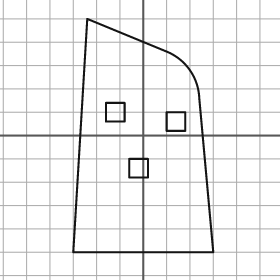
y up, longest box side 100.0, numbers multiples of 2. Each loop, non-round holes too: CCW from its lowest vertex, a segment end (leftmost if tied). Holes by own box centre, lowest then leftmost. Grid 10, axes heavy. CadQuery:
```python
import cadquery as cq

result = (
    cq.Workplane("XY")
    .moveTo(-30.0, -50.0)
    .lineTo(30.0, -50.0)
    .lineTo(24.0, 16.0)
    .threePointArc((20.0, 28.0), (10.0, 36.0))
    .lineTo(-24.0, 50.0)
    .close()
    .moveTo(-6.0, -18.0)
    .lineTo(2.0, -18.0)
    .lineTo(2.0, -10.0)
    .lineTo(-6.0, -10.0)
    .close()
    .moveTo(10.0, 2.0)
    .lineTo(18.0, 2.0)
    .lineTo(18.0, 10.0)
    .lineTo(10.0, 10.0)
    .close()
    .moveTo(-16.0, 6.0)
    .lineTo(-8.0, 6.0)
    .lineTo(-8.0, 14.0)
    .lineTo(-16.0, 14.0)
    .close()
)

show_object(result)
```